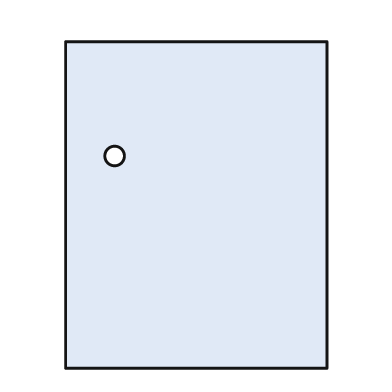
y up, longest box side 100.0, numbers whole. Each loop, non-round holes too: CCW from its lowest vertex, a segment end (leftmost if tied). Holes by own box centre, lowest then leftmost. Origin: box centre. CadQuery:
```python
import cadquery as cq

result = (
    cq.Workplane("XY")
    .moveTo(-40.0, -50.0)
    .lineTo(40.0, -50.0)
    .lineTo(40.0, 50.0)
    .lineTo(-40.0, 50.0)
    .close()
    .moveTo(-25.0, 15.0)
    .circle(3.0)
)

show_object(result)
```